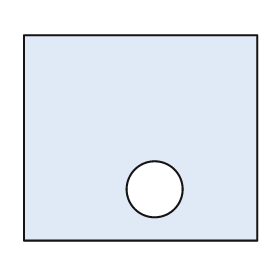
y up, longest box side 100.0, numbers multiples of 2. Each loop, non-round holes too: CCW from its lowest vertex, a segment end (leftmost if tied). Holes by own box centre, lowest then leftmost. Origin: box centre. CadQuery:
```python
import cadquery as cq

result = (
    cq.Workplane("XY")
    .moveTo(-50.0, -44.0)
    .lineTo(50.0, -44.0)
    .lineTo(50.0, 44.0)
    .lineTo(-50.0, 44.0)
    .close()
    .moveTo(6.0, -22.0)
    .circle(12.0)
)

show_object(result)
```